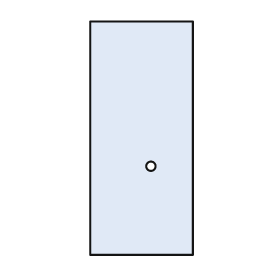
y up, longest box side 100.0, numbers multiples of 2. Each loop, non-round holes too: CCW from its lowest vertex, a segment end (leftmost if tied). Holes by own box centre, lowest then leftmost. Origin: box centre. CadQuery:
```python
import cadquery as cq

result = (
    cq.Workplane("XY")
    .moveTo(-22.0, -50.0)
    .lineTo(22.0, -50.0)
    .lineTo(22.0, 50.0)
    .lineTo(-22.0, 50.0)
    .close()
    .moveTo(4.0, -12.0)
    .circle(2.0)
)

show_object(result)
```